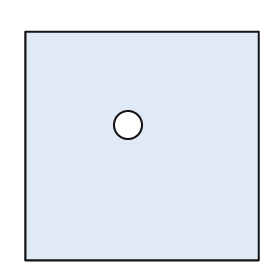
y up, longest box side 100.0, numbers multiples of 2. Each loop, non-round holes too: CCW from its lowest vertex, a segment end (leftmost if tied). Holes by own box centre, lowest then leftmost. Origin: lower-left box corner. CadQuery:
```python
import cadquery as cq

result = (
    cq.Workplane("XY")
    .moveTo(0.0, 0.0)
    .lineTo(100.0, 0.0)
    .lineTo(100.0, 98.0)
    .lineTo(0.0, 98.0)
    .close()
    .moveTo(44.0, 58.0)
    .circle(6.0)
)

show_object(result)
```